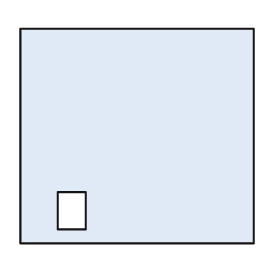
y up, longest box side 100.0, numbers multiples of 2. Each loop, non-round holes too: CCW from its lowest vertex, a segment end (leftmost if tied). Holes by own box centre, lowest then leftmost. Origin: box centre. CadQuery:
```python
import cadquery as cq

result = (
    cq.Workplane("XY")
    .moveTo(-50.0, -46.0)
    .lineTo(50.0, -46.0)
    .lineTo(50.0, 46.0)
    .lineTo(-50.0, 46.0)
    .close()
    .moveTo(-34.0, -40.0)
    .lineTo(-22.0, -40.0)
    .lineTo(-22.0, -24.0)
    .lineTo(-34.0, -24.0)
    .close()
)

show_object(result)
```